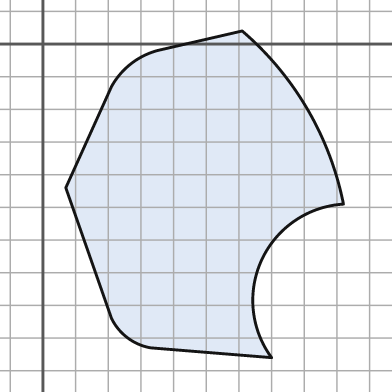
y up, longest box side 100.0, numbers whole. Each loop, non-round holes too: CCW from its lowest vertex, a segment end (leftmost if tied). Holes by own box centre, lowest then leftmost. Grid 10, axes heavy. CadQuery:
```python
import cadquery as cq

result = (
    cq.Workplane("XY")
    .moveTo(70.0, -96.0)
    .threePointArc((67.0, -66.0), (92.0, -49.0))
    .threePointArc((81.0, -20.0), (61.0, 4.0))
    .lineTo(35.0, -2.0)
    .threePointArc((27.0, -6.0), (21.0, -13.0))
    .lineTo(7.0, -44.0)
    .lineTo(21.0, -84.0)
    .threePointArc((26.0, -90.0), (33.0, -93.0))
    .close()
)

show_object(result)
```